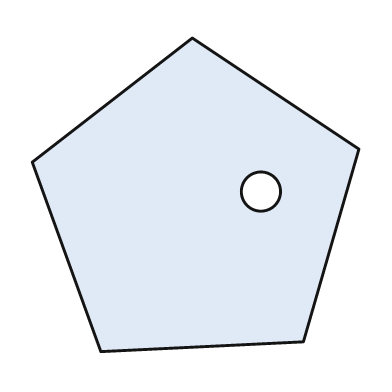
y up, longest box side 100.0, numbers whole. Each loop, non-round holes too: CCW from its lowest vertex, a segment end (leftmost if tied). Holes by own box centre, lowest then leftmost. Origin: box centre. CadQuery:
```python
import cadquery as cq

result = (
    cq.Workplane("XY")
    .moveTo(-29.0, -48.0)
    .lineTo(33.0, -45.0)
    .lineTo(50.0, 14.0)
    .lineTo(-1.0, 48.0)
    .lineTo(-50.0, 10.0)
    .close()
    .moveTo(20.0, 1.0)
    .circle(6.0)
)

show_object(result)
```